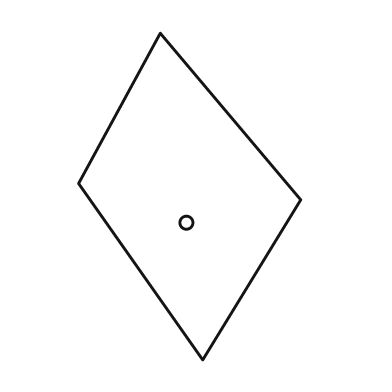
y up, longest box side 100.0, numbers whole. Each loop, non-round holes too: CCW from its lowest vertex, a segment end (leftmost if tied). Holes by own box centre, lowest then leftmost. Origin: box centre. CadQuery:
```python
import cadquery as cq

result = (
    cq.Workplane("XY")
    .moveTo(4.0, -50.0)
    .lineTo(34.0, -1.0)
    .lineTo(-9.0, 50.0)
    .lineTo(-34.0, 4.0)
    .close()
    .moveTo(-1.0, -8.0)
    .circle(2.0)
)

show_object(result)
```